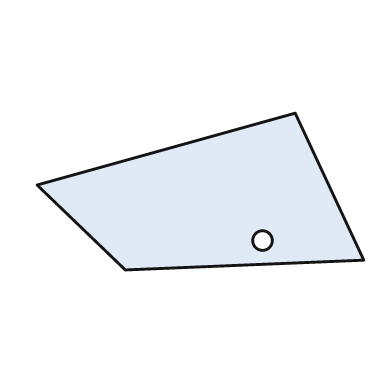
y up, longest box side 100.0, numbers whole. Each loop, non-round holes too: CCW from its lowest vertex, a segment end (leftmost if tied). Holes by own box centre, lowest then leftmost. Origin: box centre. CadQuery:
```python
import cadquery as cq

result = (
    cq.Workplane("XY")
    .moveTo(-23.0, -24.0)
    .lineTo(50.0, -21.0)
    .lineTo(29.0, 24.0)
    .lineTo(-50.0, 2.0)
    .close()
    .moveTo(19.0, -15.0)
    .circle(3.0)
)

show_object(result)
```